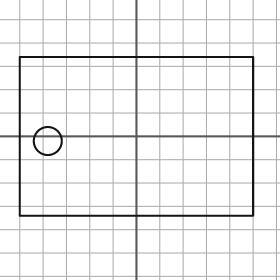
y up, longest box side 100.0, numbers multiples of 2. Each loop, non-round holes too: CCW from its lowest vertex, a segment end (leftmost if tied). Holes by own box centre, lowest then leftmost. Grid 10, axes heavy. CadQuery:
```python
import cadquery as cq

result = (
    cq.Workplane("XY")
    .moveTo(-50.0, -34.0)
    .lineTo(50.0, -34.0)
    .lineTo(50.0, 34.0)
    .lineTo(-50.0, 34.0)
    .close()
    .moveTo(-38.0, -2.0)
    .circle(6.0)
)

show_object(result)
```